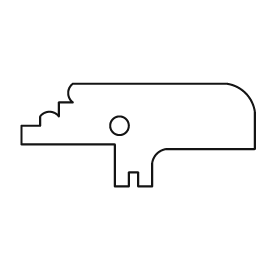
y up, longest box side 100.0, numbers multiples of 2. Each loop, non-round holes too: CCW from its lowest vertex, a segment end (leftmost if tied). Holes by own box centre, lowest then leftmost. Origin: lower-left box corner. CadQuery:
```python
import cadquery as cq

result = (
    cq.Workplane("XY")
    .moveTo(40.0, 0.0)
    .lineTo(46.0, 0.0)
    .lineTo(46.0, 6.0)
    .lineTo(50.0, 6.0)
    .lineTo(50.0, 0.0)
    .lineTo(56.0, 0.0)
    .lineTo(56.0, 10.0)
    .threePointArc((58.0, 14.0), (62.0, 16.0))
    .lineTo(100.0, 16.0)
    .lineTo(100.0, 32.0)
    .threePointArc((96.0, 40.0), (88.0, 44.0))
    .lineTo(22.0, 44.0)
    .threePointArc((20.0, 40.0), (22.0, 36.0))
    .lineTo(16.0, 36.0)
    .lineTo(16.0, 30.0)
    .threePointArc((12.0, 32.0), (8.0, 30.0))
    .lineTo(8.0, 26.0)
    .lineTo(0.0, 26.0)
    .lineTo(0.0, 18.0)
    .lineTo(40.0, 18.0)
    .close()
    .moveTo(42.0, 26.0)
    .circle(4.0)
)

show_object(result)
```